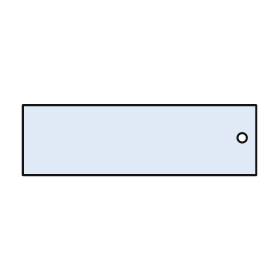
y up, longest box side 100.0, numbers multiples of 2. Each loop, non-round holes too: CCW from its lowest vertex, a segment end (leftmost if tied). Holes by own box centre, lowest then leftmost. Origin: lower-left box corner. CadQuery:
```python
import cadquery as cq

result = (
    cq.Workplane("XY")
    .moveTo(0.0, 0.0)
    .lineTo(100.0, 0.0)
    .lineTo(100.0, 30.0)
    .lineTo(0.0, 30.0)
    .close()
    .moveTo(94.0, 16.0)
    .circle(2.0)
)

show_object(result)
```